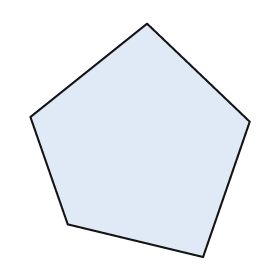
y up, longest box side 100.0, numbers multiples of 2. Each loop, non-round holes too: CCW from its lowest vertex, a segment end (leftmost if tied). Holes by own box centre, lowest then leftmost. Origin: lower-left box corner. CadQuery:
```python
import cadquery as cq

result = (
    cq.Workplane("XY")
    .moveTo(74.0, 0.0)
    .lineTo(94.0, 58.0)
    .lineTo(50.0, 100.0)
    .lineTo(0.0, 60.0)
    .lineTo(16.0, 14.0)
    .close()
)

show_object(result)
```